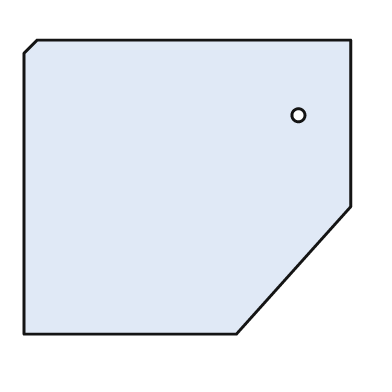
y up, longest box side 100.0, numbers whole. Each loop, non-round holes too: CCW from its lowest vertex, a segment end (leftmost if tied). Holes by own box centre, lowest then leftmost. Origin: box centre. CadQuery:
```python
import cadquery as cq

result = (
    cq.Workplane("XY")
    .moveTo(-50.0, -45.0)
    .lineTo(15.0, -45.0)
    .lineTo(50.0, -6.0)
    .lineTo(50.0, 45.0)
    .lineTo(-46.0, 45.0)
    .lineTo(-50.0, 41.0)
    .close()
    .moveTo(34.0, 22.0)
    .circle(2.0)
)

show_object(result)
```